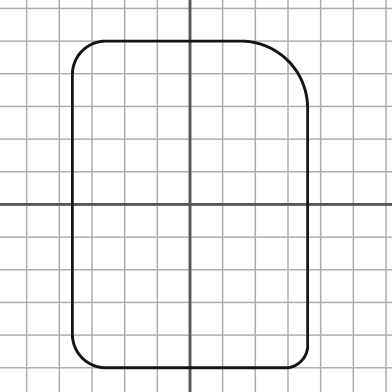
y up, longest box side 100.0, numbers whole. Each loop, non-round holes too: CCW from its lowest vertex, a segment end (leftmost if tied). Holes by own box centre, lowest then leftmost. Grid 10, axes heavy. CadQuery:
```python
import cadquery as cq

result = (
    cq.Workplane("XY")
    .moveTo(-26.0, -50.0)
    .lineTo(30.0, -50.0)
    .threePointArc((34.0, -48.0), (36.0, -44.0))
    .lineTo(36.0, 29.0)
    .threePointArc((30.0, 44.0), (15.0, 50.0))
    .lineTo(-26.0, 50.0)
    .threePointArc((-33.0, 47.0), (-36.0, 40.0))
    .lineTo(-36.0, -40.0)
    .threePointArc((-33.0, -47.0), (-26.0, -50.0))
    .close()
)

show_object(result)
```